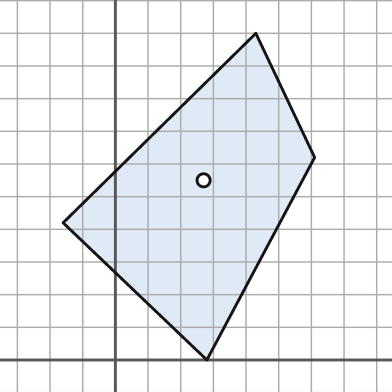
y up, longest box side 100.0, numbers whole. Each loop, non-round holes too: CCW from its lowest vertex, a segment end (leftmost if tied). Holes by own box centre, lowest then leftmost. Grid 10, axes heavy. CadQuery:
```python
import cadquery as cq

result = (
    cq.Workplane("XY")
    .moveTo(28.0, 0.0)
    .lineTo(61.0, 62.0)
    .lineTo(43.0, 100.0)
    .lineTo(-16.0, 42.0)
    .close()
    .moveTo(27.0, 55.0)
    .circle(2.0)
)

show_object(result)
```